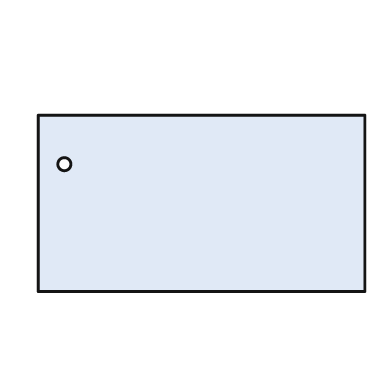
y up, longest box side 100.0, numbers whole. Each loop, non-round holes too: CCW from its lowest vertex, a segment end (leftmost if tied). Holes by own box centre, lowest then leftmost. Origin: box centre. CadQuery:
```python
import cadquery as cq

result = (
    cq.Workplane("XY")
    .moveTo(-50.0, -27.0)
    .lineTo(50.0, -27.0)
    .lineTo(50.0, 27.0)
    .lineTo(-50.0, 27.0)
    .close()
    .moveTo(-42.0, 12.0)
    .circle(2.0)
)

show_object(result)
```